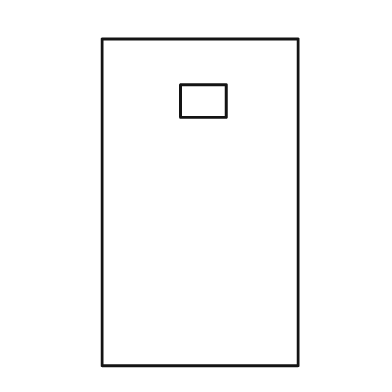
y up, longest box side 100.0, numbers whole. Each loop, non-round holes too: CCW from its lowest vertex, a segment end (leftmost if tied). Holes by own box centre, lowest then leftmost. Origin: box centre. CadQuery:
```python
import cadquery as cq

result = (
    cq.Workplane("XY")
    .moveTo(-30.0, -50.0)
    .lineTo(30.0, -50.0)
    .lineTo(30.0, 50.0)
    .lineTo(-30.0, 50.0)
    .close()
    .moveTo(-6.0, 26.0)
    .lineTo(8.0, 26.0)
    .lineTo(8.0, 36.0)
    .lineTo(-6.0, 36.0)
    .close()
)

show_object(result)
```